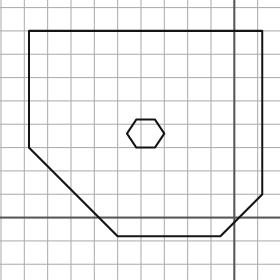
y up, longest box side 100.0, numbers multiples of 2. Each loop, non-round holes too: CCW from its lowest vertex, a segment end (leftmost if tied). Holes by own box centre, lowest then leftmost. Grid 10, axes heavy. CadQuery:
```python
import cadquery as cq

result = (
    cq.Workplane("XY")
    .moveTo(-50.0, -8.0)
    .lineTo(-6.0, -8.0)
    .lineTo(12.0, 10.0)
    .lineTo(12.0, 80.0)
    .lineTo(-88.0, 80.0)
    .lineTo(-88.0, 30.0)
    .close()
    .moveTo(-42.0, 30.0)
    .lineTo(-34.0, 30.0)
    .lineTo(-30.0, 36.0)
    .lineTo(-34.0, 42.0)
    .lineTo(-42.0, 42.0)
    .lineTo(-46.0, 36.0)
    .close()
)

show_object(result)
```